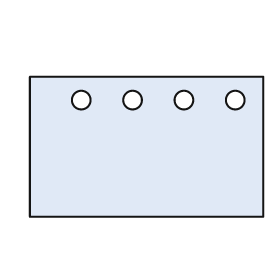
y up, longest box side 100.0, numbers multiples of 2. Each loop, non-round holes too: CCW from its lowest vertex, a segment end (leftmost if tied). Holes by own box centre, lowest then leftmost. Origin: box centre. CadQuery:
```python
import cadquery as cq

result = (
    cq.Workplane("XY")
    .moveTo(-50.0, -30.0)
    .lineTo(50.0, -30.0)
    .lineTo(50.0, 30.0)
    .lineTo(-50.0, 30.0)
    .close()
    .moveTo(-28.0, 20.0)
    .circle(4.0)
    .moveTo(-6.0, 20.0)
    .circle(4.0)
    .moveTo(16.0, 20.0)
    .circle(4.0)
    .moveTo(38.0, 20.0)
    .circle(4.0)
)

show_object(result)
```